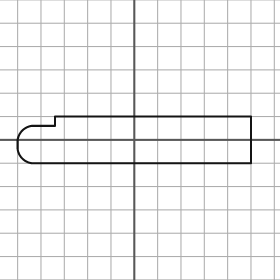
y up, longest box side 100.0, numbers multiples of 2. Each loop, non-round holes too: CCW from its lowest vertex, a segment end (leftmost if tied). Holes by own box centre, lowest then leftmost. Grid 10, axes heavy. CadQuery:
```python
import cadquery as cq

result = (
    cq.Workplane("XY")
    .moveTo(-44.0, -10.0)
    .lineTo(50.0, -10.0)
    .lineTo(50.0, 10.0)
    .lineTo(-34.0, 10.0)
    .lineTo(-34.0, 6.0)
    .lineTo(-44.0, 6.0)
    .threePointArc((-48.0, 4.0), (-50.0, 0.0))
    .lineTo(-50.0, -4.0)
    .threePointArc((-48.0, -8.0), (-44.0, -10.0))
    .close()
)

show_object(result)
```